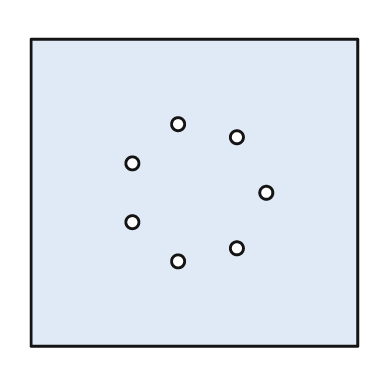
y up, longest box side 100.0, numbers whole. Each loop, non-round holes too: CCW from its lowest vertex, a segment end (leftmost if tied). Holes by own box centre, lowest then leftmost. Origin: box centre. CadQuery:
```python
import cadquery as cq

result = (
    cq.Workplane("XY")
    .moveTo(-50.0, -47.0)
    .lineTo(50.0, -47.0)
    .lineTo(50.0, 47.0)
    .lineTo(-50.0, 47.0)
    .close()
    .moveTo(-5.0, -21.0)
    .circle(2.0)
    .moveTo(13.0, -17.0)
    .circle(2.0)
    .moveTo(-19.0, -9.0)
    .circle(2.0)
    .moveTo(22.0, 0.0)
    .circle(2.0)
    .moveTo(-19.0, 9.0)
    .circle(2.0)
    .moveTo(13.0, 17.0)
    .circle(2.0)
    .moveTo(-5.0, 21.0)
    .circle(2.0)
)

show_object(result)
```